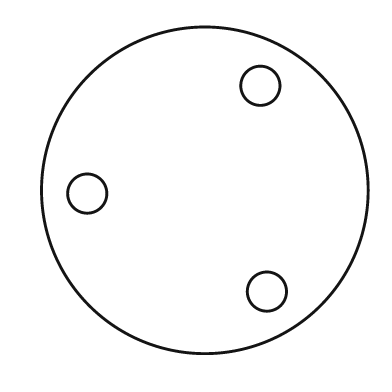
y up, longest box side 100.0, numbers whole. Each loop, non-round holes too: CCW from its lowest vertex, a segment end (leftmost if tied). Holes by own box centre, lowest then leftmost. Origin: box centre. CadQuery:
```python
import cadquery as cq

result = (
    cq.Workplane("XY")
    .moveTo(0.0, 0.0)
    .circle(50.0)
    .moveTo(19.0, -31.0)
    .circle(6.0)
    .moveTo(-36.0, -1.0)
    .circle(6.0)
    .moveTo(17.0, 32.0)
    .circle(6.0)
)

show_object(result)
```